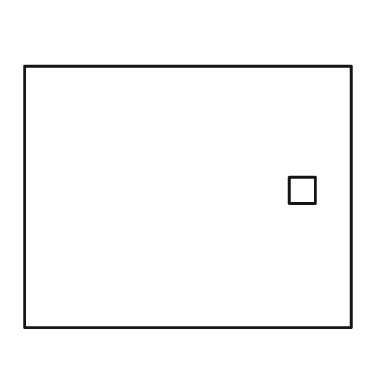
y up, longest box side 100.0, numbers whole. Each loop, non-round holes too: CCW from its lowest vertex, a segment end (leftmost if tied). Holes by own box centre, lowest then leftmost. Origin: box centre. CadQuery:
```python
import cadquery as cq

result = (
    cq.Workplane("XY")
    .moveTo(-50.0, -40.0)
    .lineTo(50.0, -40.0)
    .lineTo(50.0, 40.0)
    .lineTo(-50.0, 40.0)
    .close()
    .moveTo(31.0, -2.0)
    .lineTo(39.0, -2.0)
    .lineTo(39.0, 6.0)
    .lineTo(31.0, 6.0)
    .close()
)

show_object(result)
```